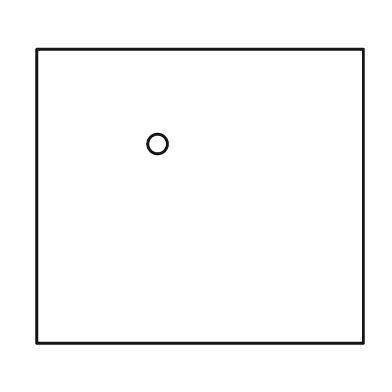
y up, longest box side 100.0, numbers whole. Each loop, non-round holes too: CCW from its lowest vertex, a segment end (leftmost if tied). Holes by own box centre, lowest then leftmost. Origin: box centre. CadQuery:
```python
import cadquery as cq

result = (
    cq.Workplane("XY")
    .moveTo(-50.0, -45.0)
    .lineTo(50.0, -45.0)
    .lineTo(50.0, 45.0)
    .lineTo(-50.0, 45.0)
    .close()
    .moveTo(-13.0, 16.0)
    .circle(3.0)
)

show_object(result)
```